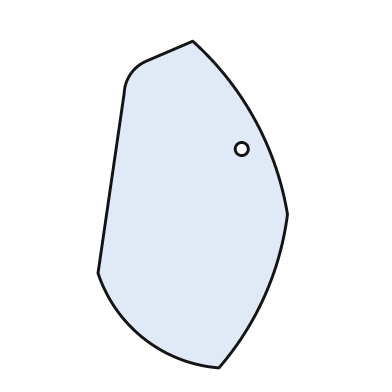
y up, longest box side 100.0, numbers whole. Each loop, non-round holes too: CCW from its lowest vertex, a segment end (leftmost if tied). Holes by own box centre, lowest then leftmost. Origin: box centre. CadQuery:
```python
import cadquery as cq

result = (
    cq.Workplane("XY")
    .moveTo(8.0, -50.0)
    .threePointArc((22.0, -28.0), (29.0, -3.0))
    .threePointArc((19.0, 26.0), (0.0, 50.0))
    .lineTo(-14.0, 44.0)
    .threePointArc((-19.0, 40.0), (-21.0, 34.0))
    .lineTo(-29.0, -21.0)
    .threePointArc((-15.0, -41.0), (8.0, -50.0))
    .close()
    .moveTo(15.0, 17.0)
    .circle(2.0)
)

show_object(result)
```